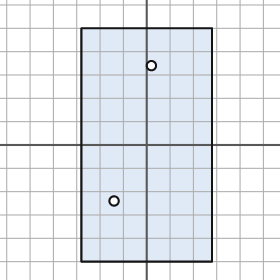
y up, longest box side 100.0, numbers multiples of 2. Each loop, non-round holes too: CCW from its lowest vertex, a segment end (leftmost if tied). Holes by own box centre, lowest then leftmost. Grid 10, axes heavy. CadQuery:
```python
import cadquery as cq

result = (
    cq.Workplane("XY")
    .moveTo(-28.0, -50.0)
    .lineTo(28.0, -50.0)
    .lineTo(28.0, 50.0)
    .lineTo(-28.0, 50.0)
    .close()
    .moveTo(-14.0, -24.0)
    .circle(2.0)
    .moveTo(2.0, 34.0)
    .circle(2.0)
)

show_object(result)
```